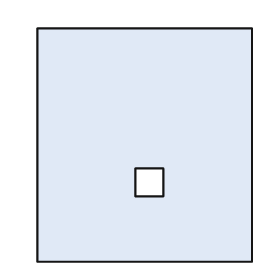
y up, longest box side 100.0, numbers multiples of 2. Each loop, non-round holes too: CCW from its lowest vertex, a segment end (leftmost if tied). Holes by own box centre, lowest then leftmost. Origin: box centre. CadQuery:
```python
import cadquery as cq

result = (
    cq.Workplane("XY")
    .moveTo(-46.0, -50.0)
    .lineTo(46.0, -50.0)
    .lineTo(46.0, 50.0)
    .lineTo(-46.0, 50.0)
    .close()
    .moveTo(-4.0, -22.0)
    .lineTo(8.0, -22.0)
    .lineTo(8.0, -10.0)
    .lineTo(-4.0, -10.0)
    .close()
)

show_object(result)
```